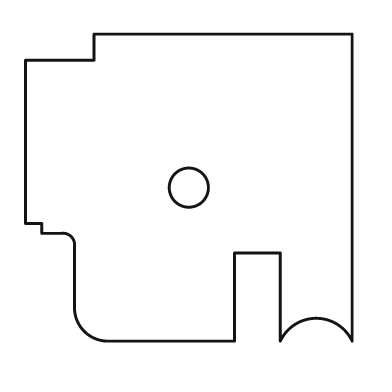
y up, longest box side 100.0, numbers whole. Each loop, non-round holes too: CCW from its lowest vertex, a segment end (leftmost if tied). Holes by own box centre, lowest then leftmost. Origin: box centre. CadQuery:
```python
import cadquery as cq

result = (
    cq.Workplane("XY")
    .moveTo(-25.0, -47.0)
    .lineTo(14.0, -47.0)
    .lineTo(14.0, -20.0)
    .lineTo(28.0, -20.0)
    .lineTo(28.0, -47.0)
    .threePointArc((39.0, -40.0), (50.0, -47.0))
    .lineTo(50.0, 47.0)
    .lineTo(-29.0, 47.0)
    .lineTo(-29.0, 39.0)
    .lineTo(-50.0, 39.0)
    .lineTo(-50.0, -11.0)
    .lineTo(-45.0, -11.0)
    .lineTo(-45.0, -14.0)
    .lineTo(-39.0, -14.0)
    .threePointArc((-36.0, -15.0), (-35.0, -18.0))
    .lineTo(-35.0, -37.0)
    .threePointArc((-32.0, -44.0), (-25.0, -47.0))
    .close()
    .moveTo(0.0, 0.0)
    .circle(6.0)
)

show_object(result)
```